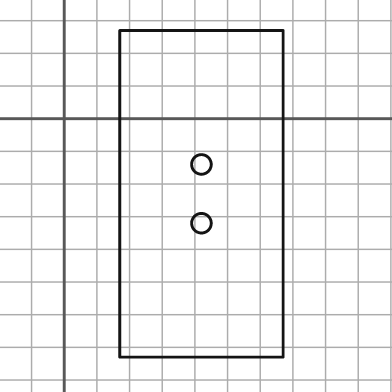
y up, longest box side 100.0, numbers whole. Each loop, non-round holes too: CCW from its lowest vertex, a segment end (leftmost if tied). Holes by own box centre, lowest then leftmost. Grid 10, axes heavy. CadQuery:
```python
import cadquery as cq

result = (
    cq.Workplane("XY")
    .moveTo(17.0, -73.0)
    .lineTo(67.0, -73.0)
    .lineTo(67.0, 27.0)
    .lineTo(17.0, 27.0)
    .close()
    .moveTo(42.0, -32.0)
    .circle(3.0)
    .moveTo(42.0, -14.0)
    .circle(3.0)
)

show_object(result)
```